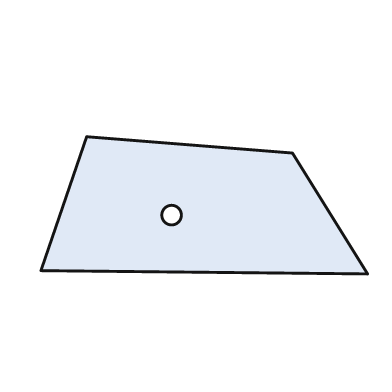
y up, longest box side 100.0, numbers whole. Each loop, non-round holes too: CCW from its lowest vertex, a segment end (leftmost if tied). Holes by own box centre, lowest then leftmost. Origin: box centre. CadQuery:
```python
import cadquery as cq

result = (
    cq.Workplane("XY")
    .moveTo(50.0, -21.0)
    .lineTo(27.0, 16.0)
    .lineTo(-36.0, 21.0)
    .lineTo(-50.0, -20.0)
    .close()
    .moveTo(-10.0, -3.0)
    .circle(3.0)
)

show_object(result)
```